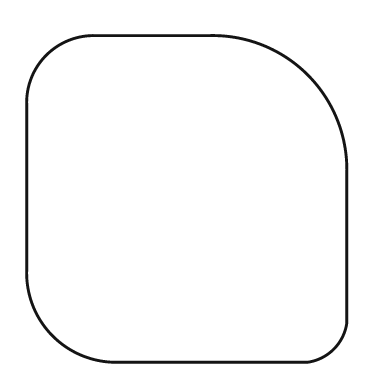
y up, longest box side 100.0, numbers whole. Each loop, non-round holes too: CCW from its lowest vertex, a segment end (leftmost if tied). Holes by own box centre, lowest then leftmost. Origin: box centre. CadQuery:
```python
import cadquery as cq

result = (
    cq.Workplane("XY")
    .moveTo(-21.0, -50.0)
    .lineTo(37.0, -50.0)
    .threePointArc((45.0, -46.0), (49.0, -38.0))
    .lineTo(49.0, 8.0)
    .threePointArc((37.0, 38.0), (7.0, 50.0))
    .lineTo(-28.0, 50.0)
    .threePointArc((-43.0, 44.0), (-49.0, 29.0))
    .lineTo(-49.0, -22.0)
    .threePointArc((-41.0, -42.0), (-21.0, -50.0))
    .close()
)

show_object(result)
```